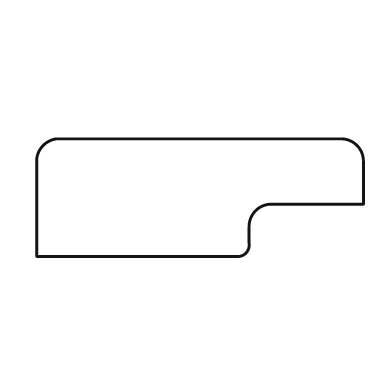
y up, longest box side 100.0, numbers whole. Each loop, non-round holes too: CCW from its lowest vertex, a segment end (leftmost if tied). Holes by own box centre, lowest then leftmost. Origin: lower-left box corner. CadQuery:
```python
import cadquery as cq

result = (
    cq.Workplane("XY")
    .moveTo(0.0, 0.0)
    .lineTo(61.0, 0.0)
    .threePointArc((64.0, 1.0), (65.0, 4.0))
    .lineTo(65.0, 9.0)
    .threePointArc((67.0, 14.0), (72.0, 16.0))
    .lineTo(100.0, 16.0)
    .lineTo(100.0, 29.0)
    .threePointArc((98.0, 34.0), (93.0, 36.0))
    .lineTo(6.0, 36.0)
    .threePointArc((2.0, 34.0), (0.0, 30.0))
    .close()
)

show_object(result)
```